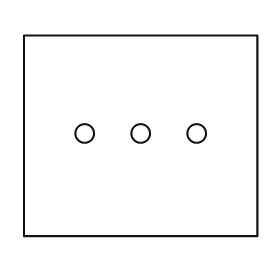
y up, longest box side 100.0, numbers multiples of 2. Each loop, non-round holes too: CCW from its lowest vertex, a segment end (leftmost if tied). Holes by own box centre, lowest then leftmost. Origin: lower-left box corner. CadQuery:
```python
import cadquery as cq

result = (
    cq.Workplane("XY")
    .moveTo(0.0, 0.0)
    .lineTo(100.0, 0.0)
    .lineTo(100.0, 86.0)
    .lineTo(0.0, 86.0)
    .close()
    .moveTo(26.0, 44.0)
    .circle(4.0)
    .moveTo(50.0, 44.0)
    .circle(4.0)
    .moveTo(74.0, 44.0)
    .circle(4.0)
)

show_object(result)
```